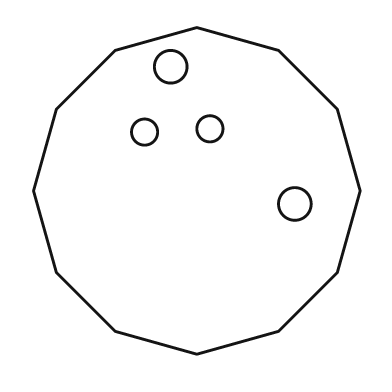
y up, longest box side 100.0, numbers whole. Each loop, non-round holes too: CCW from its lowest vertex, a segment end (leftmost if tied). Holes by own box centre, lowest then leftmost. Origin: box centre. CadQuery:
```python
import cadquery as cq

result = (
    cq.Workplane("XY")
    .moveTo(0.0, -50.0)
    .lineTo(25.0, -43.0)
    .lineTo(43.0, -25.0)
    .lineTo(50.0, 0.0)
    .lineTo(43.0, 25.0)
    .lineTo(25.0, 43.0)
    .lineTo(0.0, 50.0)
    .lineTo(-25.0, 43.0)
    .lineTo(-43.0, 25.0)
    .lineTo(-50.0, 0.0)
    .lineTo(-43.0, -25.0)
    .lineTo(-25.0, -43.0)
    .close()
    .moveTo(30.0, -4.0)
    .circle(5.0)
    .moveTo(-16.0, 18.0)
    .circle(4.0)
    .moveTo(4.0, 19.0)
    .circle(4.0)
    .moveTo(-8.0, 38.0)
    .circle(5.0)
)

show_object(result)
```